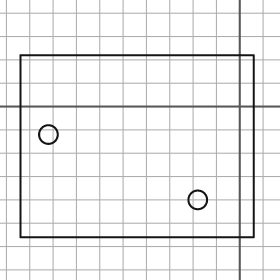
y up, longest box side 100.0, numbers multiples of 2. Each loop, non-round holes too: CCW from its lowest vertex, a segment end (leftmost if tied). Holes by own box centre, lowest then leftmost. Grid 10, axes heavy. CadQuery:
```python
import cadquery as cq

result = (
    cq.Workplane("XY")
    .moveTo(-94.0, -56.0)
    .lineTo(6.0, -56.0)
    .lineTo(6.0, 22.0)
    .lineTo(-94.0, 22.0)
    .close()
    .moveTo(-18.0, -40.0)
    .circle(4.0)
    .moveTo(-82.0, -12.0)
    .circle(4.0)
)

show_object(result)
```